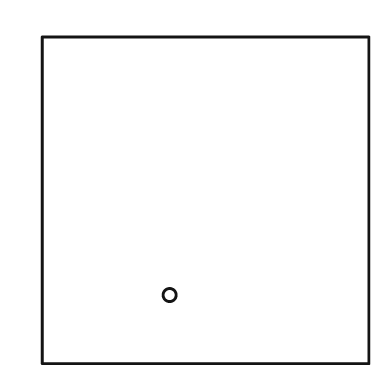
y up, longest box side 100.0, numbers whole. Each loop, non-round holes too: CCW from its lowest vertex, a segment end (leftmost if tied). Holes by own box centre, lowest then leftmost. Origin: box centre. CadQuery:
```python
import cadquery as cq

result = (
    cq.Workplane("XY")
    .moveTo(-50.0, -50.0)
    .lineTo(50.0, -50.0)
    .lineTo(50.0, 50.0)
    .lineTo(-50.0, 50.0)
    .close()
    .moveTo(-11.0, -29.0)
    .circle(2.0)
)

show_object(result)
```